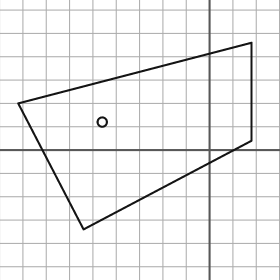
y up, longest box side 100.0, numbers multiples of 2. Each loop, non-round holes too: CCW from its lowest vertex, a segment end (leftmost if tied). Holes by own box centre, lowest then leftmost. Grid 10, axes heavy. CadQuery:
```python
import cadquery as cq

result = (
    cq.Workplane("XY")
    .moveTo(-54.0, -34.0)
    .lineTo(18.0, 4.0)
    .lineTo(18.0, 46.0)
    .lineTo(-82.0, 20.0)
    .close()
    .moveTo(-46.0, 12.0)
    .circle(2.0)
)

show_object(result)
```